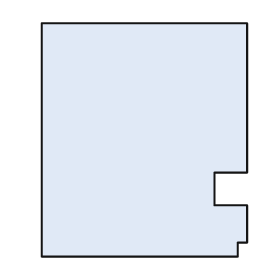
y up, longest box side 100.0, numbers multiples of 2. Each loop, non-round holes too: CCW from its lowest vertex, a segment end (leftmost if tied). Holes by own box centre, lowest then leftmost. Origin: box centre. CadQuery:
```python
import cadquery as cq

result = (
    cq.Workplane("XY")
    .moveTo(-44.0, -50.0)
    .lineTo(40.0, -50.0)
    .lineTo(40.0, -44.0)
    .lineTo(44.0, -44.0)
    .lineTo(44.0, -28.0)
    .lineTo(30.0, -28.0)
    .lineTo(30.0, -14.0)
    .lineTo(44.0, -14.0)
    .lineTo(44.0, 50.0)
    .lineTo(-44.0, 50.0)
    .close()
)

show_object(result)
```